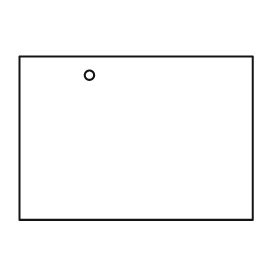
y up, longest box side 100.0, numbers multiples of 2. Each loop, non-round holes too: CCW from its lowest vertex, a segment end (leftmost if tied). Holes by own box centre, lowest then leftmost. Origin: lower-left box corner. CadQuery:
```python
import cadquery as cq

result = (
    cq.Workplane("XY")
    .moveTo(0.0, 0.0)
    .lineTo(100.0, 0.0)
    .lineTo(100.0, 70.0)
    .lineTo(0.0, 70.0)
    .close()
    .moveTo(30.0, 62.0)
    .circle(2.0)
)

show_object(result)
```